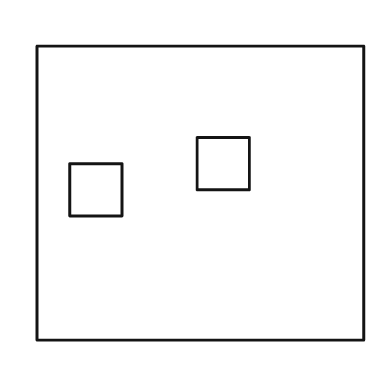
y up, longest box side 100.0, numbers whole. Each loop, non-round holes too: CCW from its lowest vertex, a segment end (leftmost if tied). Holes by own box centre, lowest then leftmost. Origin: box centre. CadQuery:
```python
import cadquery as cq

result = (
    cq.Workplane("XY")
    .moveTo(-50.0, -45.0)
    .lineTo(50.0, -45.0)
    .lineTo(50.0, 45.0)
    .lineTo(-50.0, 45.0)
    .close()
    .moveTo(-40.0, -7.0)
    .lineTo(-24.0, -7.0)
    .lineTo(-24.0, 9.0)
    .lineTo(-40.0, 9.0)
    .close()
    .moveTo(-1.0, 1.0)
    .lineTo(15.0, 1.0)
    .lineTo(15.0, 17.0)
    .lineTo(-1.0, 17.0)
    .close()
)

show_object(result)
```